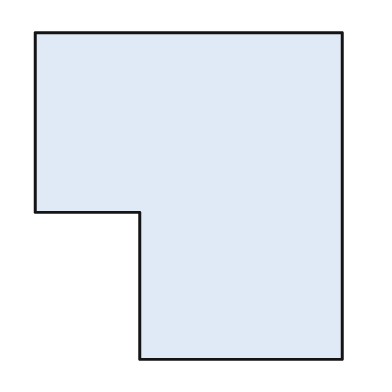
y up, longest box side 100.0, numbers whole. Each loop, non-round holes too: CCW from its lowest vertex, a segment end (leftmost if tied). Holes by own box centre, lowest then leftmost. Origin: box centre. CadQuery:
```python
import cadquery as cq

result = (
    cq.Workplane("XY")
    .moveTo(-15.0, -50.0)
    .lineTo(47.0, -50.0)
    .lineTo(47.0, 50.0)
    .lineTo(-47.0, 50.0)
    .lineTo(-47.0, -5.0)
    .lineTo(-15.0, -5.0)
    .close()
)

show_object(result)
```